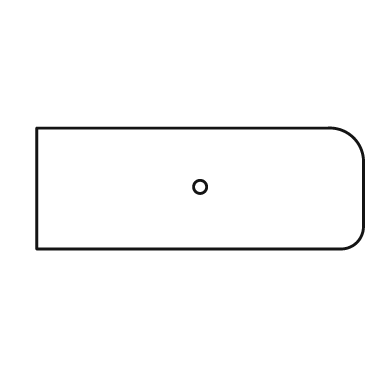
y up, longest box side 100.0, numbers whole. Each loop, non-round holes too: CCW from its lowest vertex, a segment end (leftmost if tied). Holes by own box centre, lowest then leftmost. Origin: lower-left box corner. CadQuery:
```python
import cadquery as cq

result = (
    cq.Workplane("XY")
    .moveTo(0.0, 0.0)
    .lineTo(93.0, 0.0)
    .threePointArc((98.0, 2.0), (100.0, 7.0))
    .lineTo(100.0, 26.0)
    .threePointArc((97.0, 34.0), (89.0, 37.0))
    .lineTo(0.0, 37.0)
    .close()
    .moveTo(50.0, 19.0)
    .circle(2.0)
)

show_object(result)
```